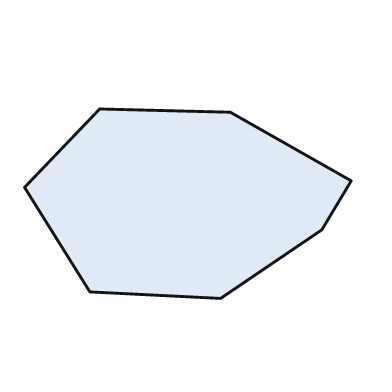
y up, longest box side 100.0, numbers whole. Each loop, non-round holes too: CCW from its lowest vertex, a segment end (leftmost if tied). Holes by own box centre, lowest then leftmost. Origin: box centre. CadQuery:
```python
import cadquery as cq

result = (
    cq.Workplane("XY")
    .moveTo(10.0, -29.0)
    .lineTo(41.0, -8.0)
    .lineTo(50.0, 7.0)
    .lineTo(13.0, 28.0)
    .lineTo(-27.0, 29.0)
    .lineTo(-50.0, 5.0)
    .lineTo(-30.0, -27.0)
    .close()
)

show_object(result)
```